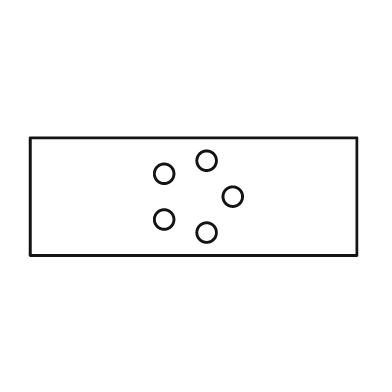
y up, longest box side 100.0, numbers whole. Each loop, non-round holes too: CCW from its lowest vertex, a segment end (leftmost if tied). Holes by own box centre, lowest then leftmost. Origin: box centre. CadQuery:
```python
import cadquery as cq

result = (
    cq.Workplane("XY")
    .moveTo(-50.0, -18.0)
    .lineTo(50.0, -18.0)
    .lineTo(50.0, 18.0)
    .lineTo(-50.0, 18.0)
    .close()
    .moveTo(4.0, -11.0)
    .circle(3.0)
    .moveTo(-9.0, -7.0)
    .circle(3.0)
    .moveTo(12.0, 0.0)
    .circle(3.0)
    .moveTo(-9.0, 7.0)
    .circle(3.0)
    .moveTo(4.0, 11.0)
    .circle(3.0)
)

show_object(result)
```